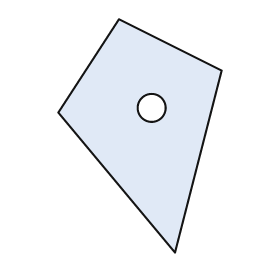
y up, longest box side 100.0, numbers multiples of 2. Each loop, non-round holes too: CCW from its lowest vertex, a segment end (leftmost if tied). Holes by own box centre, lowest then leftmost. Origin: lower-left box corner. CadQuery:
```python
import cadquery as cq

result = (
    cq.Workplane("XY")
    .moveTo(50.0, 0.0)
    .lineTo(70.0, 78.0)
    .lineTo(26.0, 100.0)
    .lineTo(0.0, 60.0)
    .close()
    .moveTo(40.0, 62.0)
    .circle(6.0)
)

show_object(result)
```